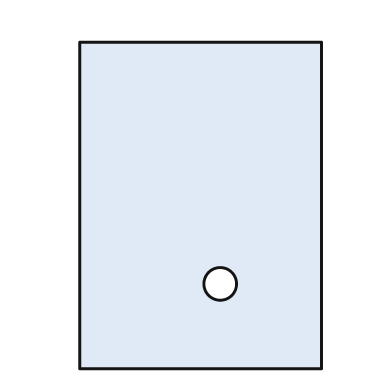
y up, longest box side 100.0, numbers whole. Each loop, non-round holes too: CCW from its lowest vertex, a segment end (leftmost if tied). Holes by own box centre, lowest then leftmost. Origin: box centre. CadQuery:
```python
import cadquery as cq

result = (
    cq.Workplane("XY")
    .moveTo(-37.0, -50.0)
    .lineTo(37.0, -50.0)
    .lineTo(37.0, 50.0)
    .lineTo(-37.0, 50.0)
    .close()
    .moveTo(6.0, -24.0)
    .circle(5.0)
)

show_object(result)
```